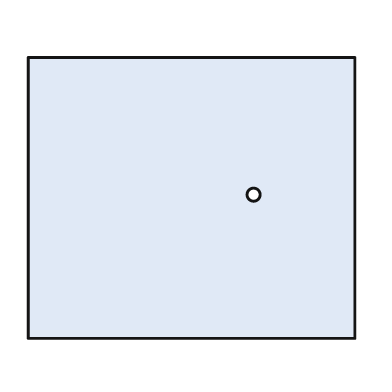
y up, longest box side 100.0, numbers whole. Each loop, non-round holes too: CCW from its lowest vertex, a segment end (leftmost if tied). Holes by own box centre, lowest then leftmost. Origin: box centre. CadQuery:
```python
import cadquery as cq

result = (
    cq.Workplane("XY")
    .moveTo(-50.0, -43.0)
    .lineTo(50.0, -43.0)
    .lineTo(50.0, 43.0)
    .lineTo(-50.0, 43.0)
    .close()
    .moveTo(19.0, 1.0)
    .circle(2.0)
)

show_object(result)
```